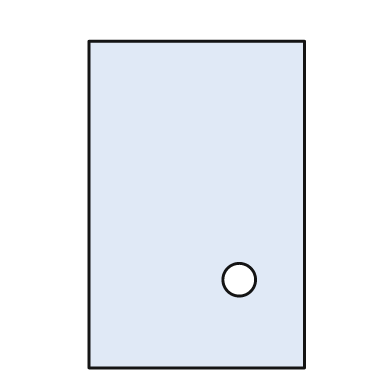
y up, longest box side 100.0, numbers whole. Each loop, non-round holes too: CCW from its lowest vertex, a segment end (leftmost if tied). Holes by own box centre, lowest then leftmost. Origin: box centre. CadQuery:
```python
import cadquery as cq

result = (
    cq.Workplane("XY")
    .moveTo(-33.0, -50.0)
    .lineTo(33.0, -50.0)
    .lineTo(33.0, 50.0)
    .lineTo(-33.0, 50.0)
    .close()
    .moveTo(13.0, -23.0)
    .circle(5.0)
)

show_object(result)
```